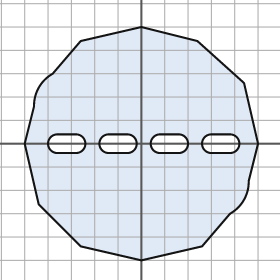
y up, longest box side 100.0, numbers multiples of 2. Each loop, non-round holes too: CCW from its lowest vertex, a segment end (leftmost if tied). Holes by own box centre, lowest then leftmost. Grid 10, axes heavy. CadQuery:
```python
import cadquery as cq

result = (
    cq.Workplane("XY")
    .moveTo(0.0, -50.0)
    .lineTo(26.0, -44.0)
    .lineTo(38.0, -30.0)
    .threePointArc((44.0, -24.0), (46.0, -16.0))
    .lineTo(50.0, 0.0)
    .lineTo(44.0, 26.0)
    .lineTo(24.0, 44.0)
    .lineTo(0.0, 50.0)
    .lineTo(-26.0, 44.0)
    .lineTo(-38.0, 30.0)
    .threePointArc((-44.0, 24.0), (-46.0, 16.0))
    .lineTo(-50.0, 0.0)
    .lineTo(-44.0, -26.0)
    .lineTo(-26.0, -44.0)
    .close()
    .moveTo(-36.0, -4.0)
    .lineTo(-28.0, -4.0)
    .threePointArc((-24.0, 0.0), (-28.0, 4.0))
    .lineTo(-36.0, 4.0)
    .threePointArc((-40.0, 0.0), (-36.0, -4.0))
    .close()
    .moveTo(-14.0, -4.0)
    .lineTo(-6.0, -4.0)
    .threePointArc((-2.0, 0.0), (-6.0, 4.0))
    .lineTo(-14.0, 4.0)
    .threePointArc((-18.0, 0.0), (-14.0, -4.0))
    .close()
    .moveTo(8.0, -4.0)
    .lineTo(16.0, -4.0)
    .threePointArc((20.0, 0.0), (16.0, 4.0))
    .lineTo(8.0, 4.0)
    .threePointArc((4.0, 0.0), (8.0, -4.0))
    .close()
    .moveTo(30.0, -4.0)
    .lineTo(38.0, -4.0)
    .threePointArc((42.0, 0.0), (38.0, 4.0))
    .lineTo(30.0, 4.0)
    .threePointArc((26.0, 0.0), (30.0, -4.0))
    .close()
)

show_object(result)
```